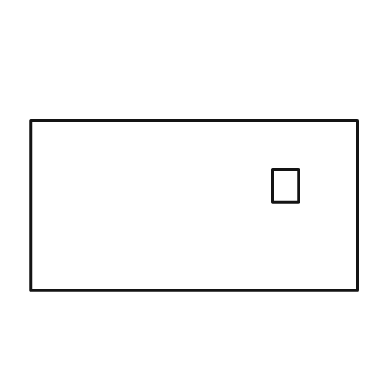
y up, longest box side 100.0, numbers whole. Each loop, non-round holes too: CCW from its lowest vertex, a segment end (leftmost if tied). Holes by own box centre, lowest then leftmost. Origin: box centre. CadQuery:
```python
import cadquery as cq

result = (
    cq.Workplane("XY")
    .moveTo(-50.0, -26.0)
    .lineTo(50.0, -26.0)
    .lineTo(50.0, 26.0)
    .lineTo(-50.0, 26.0)
    .close()
    .moveTo(24.0, 1.0)
    .lineTo(32.0, 1.0)
    .lineTo(32.0, 11.0)
    .lineTo(24.0, 11.0)
    .close()
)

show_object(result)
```